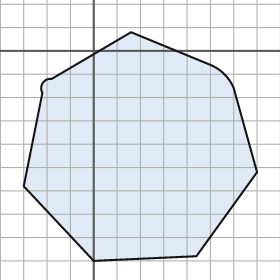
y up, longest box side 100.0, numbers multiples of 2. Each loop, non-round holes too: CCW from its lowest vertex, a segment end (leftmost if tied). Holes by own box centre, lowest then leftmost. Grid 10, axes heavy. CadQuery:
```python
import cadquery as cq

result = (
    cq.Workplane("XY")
    .moveTo(0.0, -90.0)
    .lineTo(44.0, -88.0)
    .lineTo(70.0, -52.0)
    .lineTo(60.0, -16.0)
    .threePointArc((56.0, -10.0), (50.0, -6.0))
    .lineTo(16.0, 8.0)
    .lineTo(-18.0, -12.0)
    .threePointArc((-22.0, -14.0), (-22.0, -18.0))
    .lineTo(-30.0, -58.0)
    .close()
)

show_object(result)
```